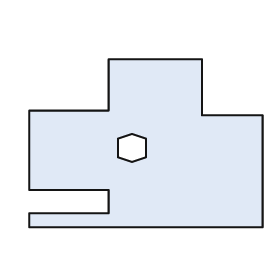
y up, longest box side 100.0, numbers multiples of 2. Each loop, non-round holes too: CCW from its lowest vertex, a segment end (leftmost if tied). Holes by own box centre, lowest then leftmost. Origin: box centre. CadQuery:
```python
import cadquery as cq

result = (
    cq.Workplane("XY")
    .moveTo(-50.0, -36.0)
    .lineTo(50.0, -36.0)
    .lineTo(50.0, 12.0)
    .lineTo(24.0, 12.0)
    .lineTo(24.0, 36.0)
    .lineTo(-16.0, 36.0)
    .lineTo(-16.0, 14.0)
    .lineTo(-50.0, 14.0)
    .lineTo(-50.0, -20.0)
    .lineTo(-16.0, -20.0)
    .lineTo(-16.0, -30.0)
    .lineTo(-50.0, -30.0)
    .close()
    .moveTo(-6.0, -8.0)
    .lineTo(0.0, -6.0)
    .lineTo(0.0, 2.0)
    .lineTo(-6.0, 4.0)
    .lineTo(-12.0, 2.0)
    .lineTo(-12.0, -6.0)
    .close()
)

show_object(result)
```